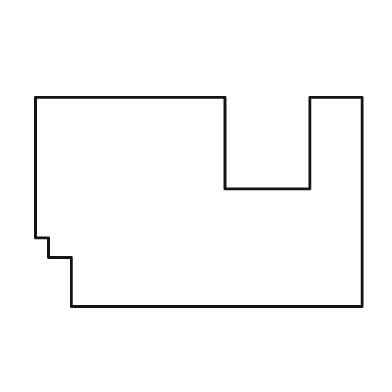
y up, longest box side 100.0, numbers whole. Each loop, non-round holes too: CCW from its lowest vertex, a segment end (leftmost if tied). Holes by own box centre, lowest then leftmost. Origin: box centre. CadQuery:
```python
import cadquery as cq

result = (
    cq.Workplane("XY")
    .moveTo(-39.0, -32.0)
    .lineTo(50.0, -32.0)
    .lineTo(50.0, 32.0)
    .lineTo(34.0, 32.0)
    .lineTo(34.0, 4.0)
    .lineTo(8.0, 4.0)
    .lineTo(8.0, 32.0)
    .lineTo(-50.0, 32.0)
    .lineTo(-50.0, -11.0)
    .lineTo(-46.0, -11.0)
    .lineTo(-46.0, -17.0)
    .lineTo(-39.0, -17.0)
    .close()
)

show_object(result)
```